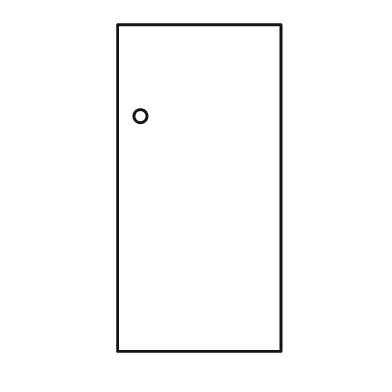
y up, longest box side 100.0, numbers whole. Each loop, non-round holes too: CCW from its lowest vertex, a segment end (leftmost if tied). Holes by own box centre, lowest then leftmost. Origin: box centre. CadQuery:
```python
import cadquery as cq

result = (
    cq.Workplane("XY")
    .moveTo(-25.0, -50.0)
    .lineTo(25.0, -50.0)
    .lineTo(25.0, 50.0)
    .lineTo(-25.0, 50.0)
    .close()
    .moveTo(-18.0, 22.0)
    .circle(2.0)
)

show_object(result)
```